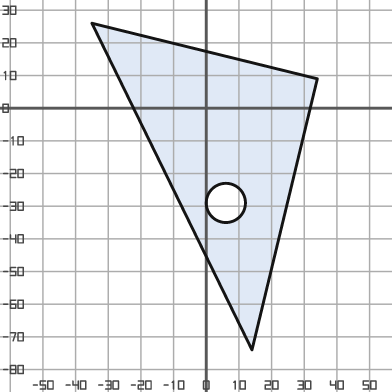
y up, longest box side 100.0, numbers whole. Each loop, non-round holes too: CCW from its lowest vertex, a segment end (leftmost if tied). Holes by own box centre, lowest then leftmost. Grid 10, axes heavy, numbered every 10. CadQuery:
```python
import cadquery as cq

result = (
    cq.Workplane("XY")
    .moveTo(14.0, -74.0)
    .lineTo(34.0, 9.0)
    .lineTo(-35.0, 26.0)
    .close()
    .moveTo(6.0, -29.0)
    .circle(6.0)
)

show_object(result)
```